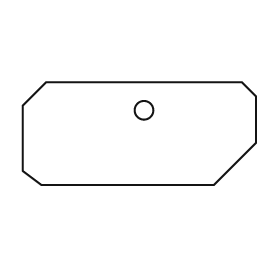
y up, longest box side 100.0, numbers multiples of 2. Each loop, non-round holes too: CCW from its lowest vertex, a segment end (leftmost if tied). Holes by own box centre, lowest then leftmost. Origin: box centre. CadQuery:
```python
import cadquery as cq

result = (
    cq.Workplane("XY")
    .moveTo(-42.0, -22.0)
    .lineTo(32.0, -22.0)
    .lineTo(50.0, -4.0)
    .lineTo(50.0, 16.0)
    .lineTo(44.0, 22.0)
    .lineTo(-40.0, 22.0)
    .lineTo(-50.0, 12.0)
    .lineTo(-50.0, -16.0)
    .close()
    .moveTo(2.0, 10.0)
    .circle(4.0)
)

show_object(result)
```